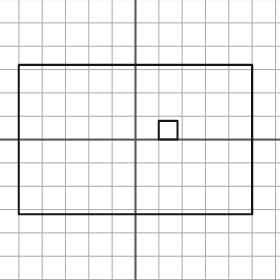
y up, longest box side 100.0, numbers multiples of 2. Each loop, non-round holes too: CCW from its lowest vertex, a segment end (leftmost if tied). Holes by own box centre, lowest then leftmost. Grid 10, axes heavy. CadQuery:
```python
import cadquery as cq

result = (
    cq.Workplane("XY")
    .moveTo(-50.0, -32.0)
    .lineTo(50.0, -32.0)
    .lineTo(50.0, 32.0)
    .lineTo(-50.0, 32.0)
    .close()
    .moveTo(10.0, 0.0)
    .lineTo(18.0, 0.0)
    .lineTo(18.0, 8.0)
    .lineTo(10.0, 8.0)
    .close()
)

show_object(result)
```